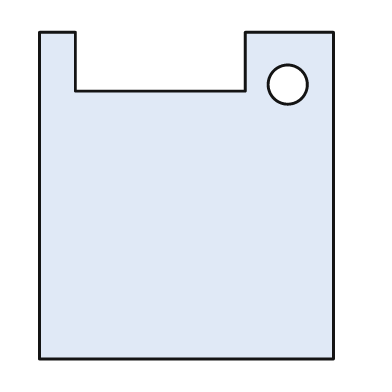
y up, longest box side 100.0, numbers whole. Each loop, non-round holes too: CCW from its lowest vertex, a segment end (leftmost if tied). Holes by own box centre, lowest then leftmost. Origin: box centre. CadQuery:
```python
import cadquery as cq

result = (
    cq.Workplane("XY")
    .moveTo(-45.0, -50.0)
    .lineTo(45.0, -50.0)
    .lineTo(45.0, 50.0)
    .lineTo(18.0, 50.0)
    .lineTo(18.0, 32.0)
    .lineTo(-34.0, 32.0)
    .lineTo(-34.0, 50.0)
    .lineTo(-45.0, 50.0)
    .close()
    .moveTo(31.0, 34.0)
    .circle(6.0)
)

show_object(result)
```